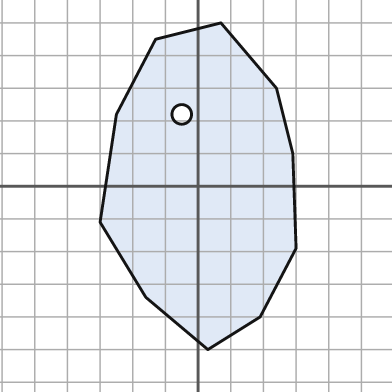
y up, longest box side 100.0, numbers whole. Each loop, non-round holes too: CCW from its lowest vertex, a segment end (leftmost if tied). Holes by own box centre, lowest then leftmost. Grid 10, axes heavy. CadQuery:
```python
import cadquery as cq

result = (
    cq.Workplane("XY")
    .moveTo(3.0, -50.0)
    .lineTo(19.0, -40.0)
    .lineTo(30.0, -19.0)
    .lineTo(29.0, 10.0)
    .lineTo(24.0, 30.0)
    .lineTo(7.0, 50.0)
    .lineTo(-13.0, 45.0)
    .lineTo(-25.0, 22.0)
    .lineTo(-30.0, -11.0)
    .lineTo(-16.0, -34.0)
    .close()
    .moveTo(-5.0, 22.0)
    .circle(3.0)
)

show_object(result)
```